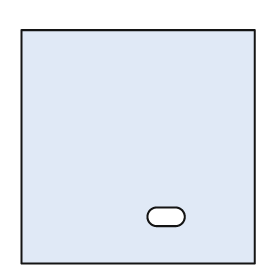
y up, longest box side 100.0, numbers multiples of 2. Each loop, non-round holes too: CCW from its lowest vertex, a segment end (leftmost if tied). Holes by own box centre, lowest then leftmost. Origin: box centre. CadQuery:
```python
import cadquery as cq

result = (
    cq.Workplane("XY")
    .moveTo(-50.0, -50.0)
    .lineTo(50.0, -50.0)
    .lineTo(50.0, 50.0)
    .lineTo(-50.0, 50.0)
    .close()
    .moveTo(8.0, -34.0)
    .lineTo(16.0, -34.0)
    .threePointArc((20.0, -30.0), (16.0, -26.0))
    .lineTo(8.0, -26.0)
    .threePointArc((4.0, -30.0), (8.0, -34.0))
    .close()
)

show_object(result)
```